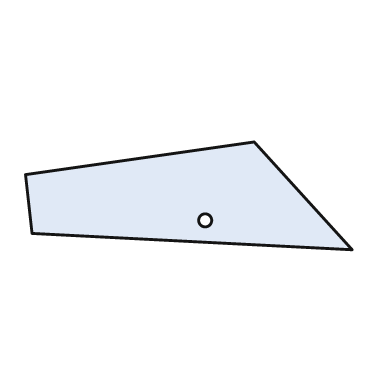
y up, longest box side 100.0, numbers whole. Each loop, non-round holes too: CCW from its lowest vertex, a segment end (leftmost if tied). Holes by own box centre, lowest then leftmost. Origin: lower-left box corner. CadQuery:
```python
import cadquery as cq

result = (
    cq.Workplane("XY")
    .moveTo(100.0, 0.0)
    .lineTo(70.0, 33.0)
    .lineTo(0.0, 23.0)
    .lineTo(2.0, 5.0)
    .close()
    .moveTo(55.0, 9.0)
    .circle(2.0)
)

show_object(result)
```